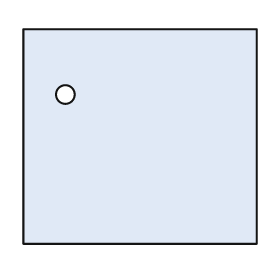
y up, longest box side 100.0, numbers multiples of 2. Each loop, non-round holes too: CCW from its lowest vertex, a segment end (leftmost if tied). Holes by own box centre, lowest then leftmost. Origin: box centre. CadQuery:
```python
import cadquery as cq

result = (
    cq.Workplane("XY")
    .moveTo(-50.0, -46.0)
    .lineTo(50.0, -46.0)
    .lineTo(50.0, 46.0)
    .lineTo(-50.0, 46.0)
    .close()
    .moveTo(-32.0, 18.0)
    .circle(4.0)
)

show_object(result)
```